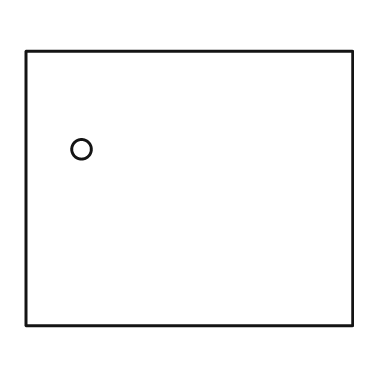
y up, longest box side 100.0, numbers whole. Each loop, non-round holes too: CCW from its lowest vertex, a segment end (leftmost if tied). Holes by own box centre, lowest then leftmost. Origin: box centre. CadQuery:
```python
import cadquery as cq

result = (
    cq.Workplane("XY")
    .moveTo(-50.0, -42.0)
    .lineTo(50.0, -42.0)
    .lineTo(50.0, 42.0)
    .lineTo(-50.0, 42.0)
    .close()
    .moveTo(-33.0, 12.0)
    .circle(3.0)
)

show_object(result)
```